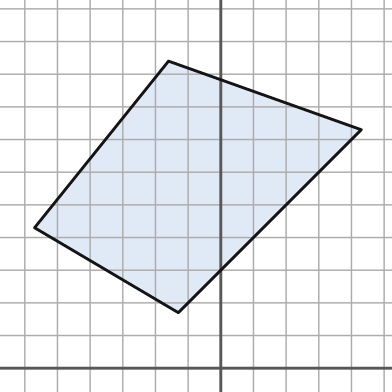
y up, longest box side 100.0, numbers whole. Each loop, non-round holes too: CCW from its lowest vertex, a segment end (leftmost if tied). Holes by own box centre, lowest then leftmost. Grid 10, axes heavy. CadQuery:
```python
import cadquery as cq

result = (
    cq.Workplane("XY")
    .moveTo(-13.0, 17.0)
    .lineTo(43.0, 73.0)
    .lineTo(-16.0, 94.0)
    .lineTo(-57.0, 43.0)
    .close()
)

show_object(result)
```